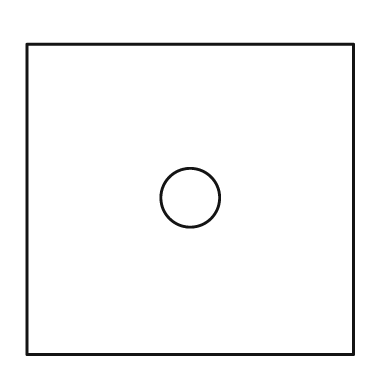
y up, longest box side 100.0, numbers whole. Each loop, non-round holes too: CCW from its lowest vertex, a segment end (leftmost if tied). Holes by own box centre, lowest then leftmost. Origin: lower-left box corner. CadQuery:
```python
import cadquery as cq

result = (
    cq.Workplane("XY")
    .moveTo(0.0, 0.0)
    .lineTo(100.0, 0.0)
    .lineTo(100.0, 95.0)
    .lineTo(0.0, 95.0)
    .close()
    .moveTo(50.0, 48.0)
    .circle(9.0)
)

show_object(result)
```